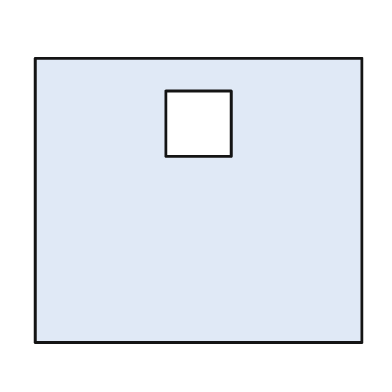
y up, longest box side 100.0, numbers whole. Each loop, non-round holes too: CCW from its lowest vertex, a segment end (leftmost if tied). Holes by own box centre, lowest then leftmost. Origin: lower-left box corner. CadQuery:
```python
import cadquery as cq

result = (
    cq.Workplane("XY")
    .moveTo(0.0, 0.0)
    .lineTo(100.0, 0.0)
    .lineTo(100.0, 87.0)
    .lineTo(0.0, 87.0)
    .close()
    .moveTo(40.0, 57.0)
    .lineTo(60.0, 57.0)
    .lineTo(60.0, 77.0)
    .lineTo(40.0, 77.0)
    .close()
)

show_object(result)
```